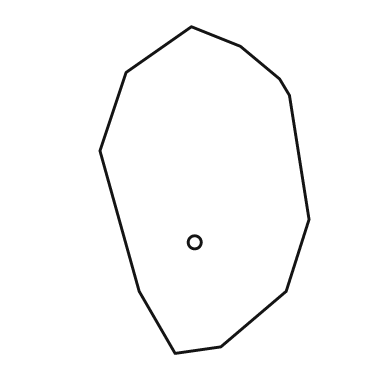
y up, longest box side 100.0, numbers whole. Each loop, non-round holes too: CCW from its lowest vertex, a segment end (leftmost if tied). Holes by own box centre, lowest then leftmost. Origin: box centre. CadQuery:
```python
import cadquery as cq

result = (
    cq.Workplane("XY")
    .moveTo(-9.0, -50.0)
    .lineTo(5.0, -48.0)
    .lineTo(25.0, -31.0)
    .lineTo(32.0, -9.0)
    .lineTo(26.0, 29.0)
    .lineTo(23.0, 34.0)
    .lineTo(11.0, 44.0)
    .lineTo(-4.0, 50.0)
    .lineTo(-24.0, 36.0)
    .lineTo(-32.0, 12.0)
    .lineTo(-20.0, -31.0)
    .close()
    .moveTo(-3.0, -16.0)
    .circle(2.0)
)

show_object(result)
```